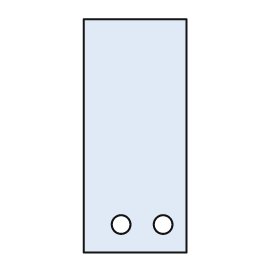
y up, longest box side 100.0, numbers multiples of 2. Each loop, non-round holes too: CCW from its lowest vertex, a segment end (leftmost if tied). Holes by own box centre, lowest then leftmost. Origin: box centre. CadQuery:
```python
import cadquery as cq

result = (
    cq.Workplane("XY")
    .moveTo(-22.0, -50.0)
    .lineTo(22.0, -50.0)
    .lineTo(22.0, 50.0)
    .lineTo(-22.0, 50.0)
    .close()
    .moveTo(-6.0, -38.0)
    .circle(4.0)
    .moveTo(12.0, -38.0)
    .circle(4.0)
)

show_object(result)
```